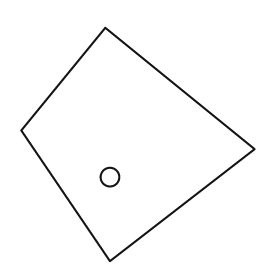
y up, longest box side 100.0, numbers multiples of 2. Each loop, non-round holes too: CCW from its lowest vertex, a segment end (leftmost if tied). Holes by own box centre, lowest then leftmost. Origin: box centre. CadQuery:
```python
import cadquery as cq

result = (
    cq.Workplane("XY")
    .moveTo(-12.0, -50.0)
    .lineTo(50.0, -2.0)
    .lineTo(-14.0, 50.0)
    .lineTo(-50.0, 6.0)
    .close()
    .moveTo(-12.0, -14.0)
    .circle(4.0)
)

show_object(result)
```